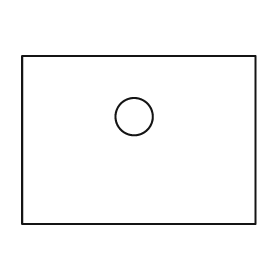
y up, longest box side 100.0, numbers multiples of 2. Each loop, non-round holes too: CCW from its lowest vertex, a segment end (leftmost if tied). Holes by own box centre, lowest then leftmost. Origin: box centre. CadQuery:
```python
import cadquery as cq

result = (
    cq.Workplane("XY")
    .moveTo(-50.0, -36.0)
    .lineTo(50.0, -36.0)
    .lineTo(50.0, 36.0)
    .lineTo(-50.0, 36.0)
    .close()
    .moveTo(-2.0, 10.0)
    .circle(8.0)
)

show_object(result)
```